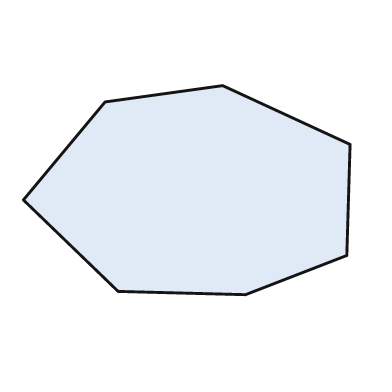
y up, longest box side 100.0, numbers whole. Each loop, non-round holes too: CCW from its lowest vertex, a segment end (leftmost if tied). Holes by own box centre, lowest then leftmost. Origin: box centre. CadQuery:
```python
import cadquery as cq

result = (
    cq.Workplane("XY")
    .moveTo(18.0, -32.0)
    .lineTo(49.0, -20.0)
    .lineTo(50.0, 14.0)
    .lineTo(11.0, 32.0)
    .lineTo(-25.0, 27.0)
    .lineTo(-50.0, -3.0)
    .lineTo(-21.0, -31.0)
    .close()
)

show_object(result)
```